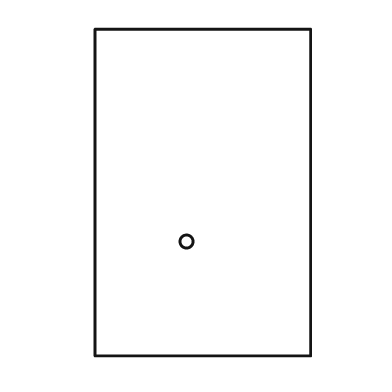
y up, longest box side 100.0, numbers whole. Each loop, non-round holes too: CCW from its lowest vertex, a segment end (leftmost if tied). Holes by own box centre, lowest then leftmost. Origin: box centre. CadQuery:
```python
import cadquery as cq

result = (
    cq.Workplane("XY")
    .moveTo(-33.0, -50.0)
    .lineTo(33.0, -50.0)
    .lineTo(33.0, 50.0)
    .lineTo(-33.0, 50.0)
    .close()
    .moveTo(-5.0, -15.0)
    .circle(2.0)
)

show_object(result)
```